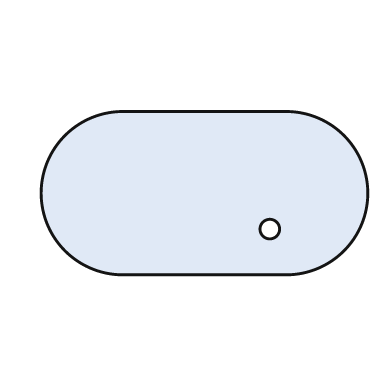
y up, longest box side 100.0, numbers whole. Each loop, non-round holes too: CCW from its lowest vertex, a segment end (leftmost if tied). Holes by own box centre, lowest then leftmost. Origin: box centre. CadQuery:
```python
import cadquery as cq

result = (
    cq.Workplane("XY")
    .moveTo(-25.0, -25.0)
    .lineTo(25.0, -25.0)
    .threePointArc((50.0, 0.0), (25.0, 25.0))
    .lineTo(-25.0, 25.0)
    .threePointArc((-50.0, 0.0), (-25.0, -25.0))
    .close()
    .moveTo(20.0, -11.0)
    .circle(3.0)
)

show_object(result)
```